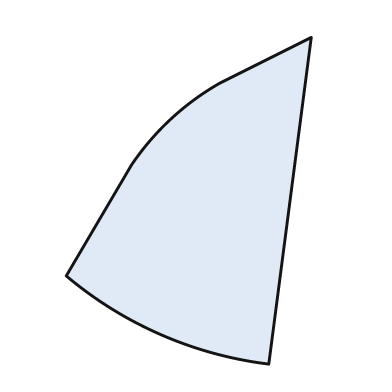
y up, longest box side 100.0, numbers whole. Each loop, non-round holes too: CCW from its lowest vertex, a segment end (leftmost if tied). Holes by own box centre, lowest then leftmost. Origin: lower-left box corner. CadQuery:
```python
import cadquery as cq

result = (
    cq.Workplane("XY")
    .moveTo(62.0, 0.0)
    .lineTo(75.0, 100.0)
    .lineTo(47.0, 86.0)
    .threePointArc((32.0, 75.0), (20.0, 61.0))
    .lineTo(0.0, 27.0)
    .threePointArc((29.0, 9.0), (62.0, 0.0))
    .close()
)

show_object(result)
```